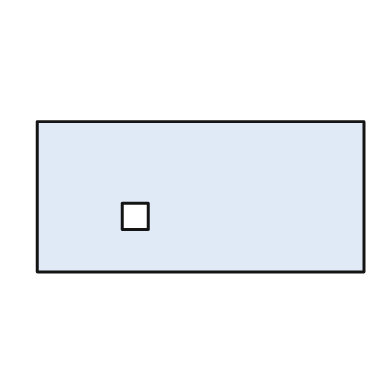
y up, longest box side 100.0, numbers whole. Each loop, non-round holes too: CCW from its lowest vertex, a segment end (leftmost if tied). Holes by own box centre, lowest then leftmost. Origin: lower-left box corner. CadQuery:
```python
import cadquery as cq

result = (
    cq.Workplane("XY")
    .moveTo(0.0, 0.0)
    .lineTo(100.0, 0.0)
    .lineTo(100.0, 46.0)
    .lineTo(0.0, 46.0)
    .close()
    .moveTo(26.0, 13.0)
    .lineTo(34.0, 13.0)
    .lineTo(34.0, 21.0)
    .lineTo(26.0, 21.0)
    .close()
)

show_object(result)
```